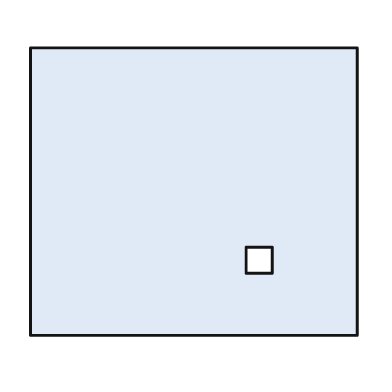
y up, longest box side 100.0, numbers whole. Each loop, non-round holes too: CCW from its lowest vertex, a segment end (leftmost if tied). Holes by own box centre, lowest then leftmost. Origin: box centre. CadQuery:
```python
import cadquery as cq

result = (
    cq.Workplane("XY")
    .moveTo(-50.0, -44.0)
    .lineTo(50.0, -44.0)
    .lineTo(50.0, 44.0)
    .lineTo(-50.0, 44.0)
    .close()
    .moveTo(16.0, -25.0)
    .lineTo(24.0, -25.0)
    .lineTo(24.0, -17.0)
    .lineTo(16.0, -17.0)
    .close()
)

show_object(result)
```